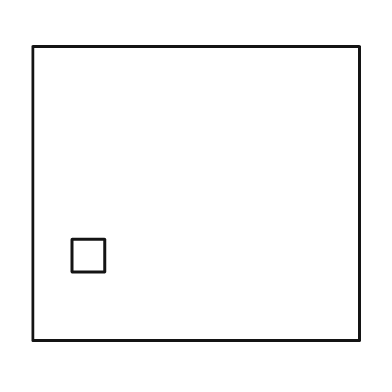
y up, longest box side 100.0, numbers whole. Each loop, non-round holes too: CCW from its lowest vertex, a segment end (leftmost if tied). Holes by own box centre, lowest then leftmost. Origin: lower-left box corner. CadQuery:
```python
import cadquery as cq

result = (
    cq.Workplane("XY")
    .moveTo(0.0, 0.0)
    .lineTo(100.0, 0.0)
    .lineTo(100.0, 90.0)
    .lineTo(0.0, 90.0)
    .close()
    .moveTo(12.0, 21.0)
    .lineTo(22.0, 21.0)
    .lineTo(22.0, 31.0)
    .lineTo(12.0, 31.0)
    .close()
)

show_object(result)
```